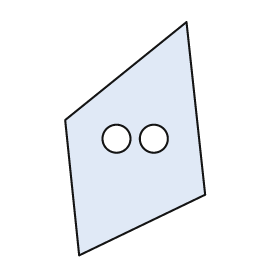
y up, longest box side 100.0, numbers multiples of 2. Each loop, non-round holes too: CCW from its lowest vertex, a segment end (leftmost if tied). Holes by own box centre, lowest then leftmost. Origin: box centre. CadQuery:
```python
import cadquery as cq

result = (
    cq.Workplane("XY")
    .moveTo(-24.0, -50.0)
    .lineTo(30.0, -24.0)
    .lineTo(22.0, 50.0)
    .lineTo(-30.0, 8.0)
    .close()
    .moveTo(-8.0, 0.0)
    .circle(6.0)
    .moveTo(8.0, 0.0)
    .circle(6.0)
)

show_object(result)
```